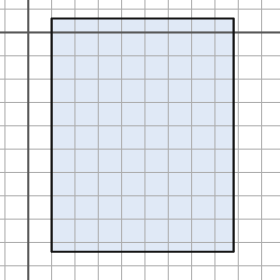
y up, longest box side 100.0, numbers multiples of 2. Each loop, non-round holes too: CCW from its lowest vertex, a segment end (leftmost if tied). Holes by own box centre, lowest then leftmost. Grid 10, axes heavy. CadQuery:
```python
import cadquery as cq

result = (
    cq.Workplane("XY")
    .moveTo(10.0, -94.0)
    .lineTo(88.0, -94.0)
    .lineTo(88.0, 6.0)
    .lineTo(10.0, 6.0)
    .close()
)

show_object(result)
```